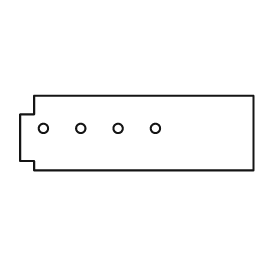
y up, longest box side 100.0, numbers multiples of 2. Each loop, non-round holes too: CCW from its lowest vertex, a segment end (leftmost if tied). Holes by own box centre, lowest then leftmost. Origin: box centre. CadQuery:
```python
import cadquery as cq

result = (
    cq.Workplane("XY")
    .moveTo(-44.0, -16.0)
    .lineTo(50.0, -16.0)
    .lineTo(50.0, 16.0)
    .lineTo(-44.0, 16.0)
    .lineTo(-44.0, 8.0)
    .lineTo(-50.0, 8.0)
    .lineTo(-50.0, -12.0)
    .lineTo(-44.0, -12.0)
    .close()
    .moveTo(-40.0, 2.0)
    .circle(2.0)
    .moveTo(-24.0, 2.0)
    .circle(2.0)
    .moveTo(-8.0, 2.0)
    .circle(2.0)
    .moveTo(8.0, 2.0)
    .circle(2.0)
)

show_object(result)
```